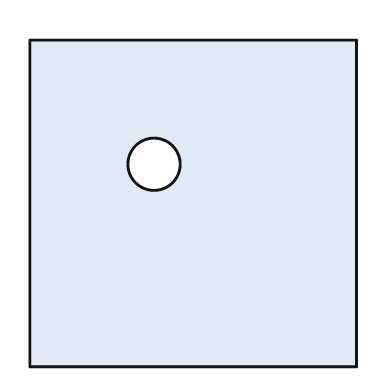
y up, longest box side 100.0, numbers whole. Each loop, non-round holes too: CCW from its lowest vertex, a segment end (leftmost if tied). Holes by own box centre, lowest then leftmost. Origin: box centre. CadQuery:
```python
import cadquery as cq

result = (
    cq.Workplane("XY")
    .moveTo(-50.0, -50.0)
    .lineTo(50.0, -50.0)
    .lineTo(50.0, 50.0)
    .lineTo(-50.0, 50.0)
    .close()
    .moveTo(-12.0, 12.0)
    .circle(8.0)
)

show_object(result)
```